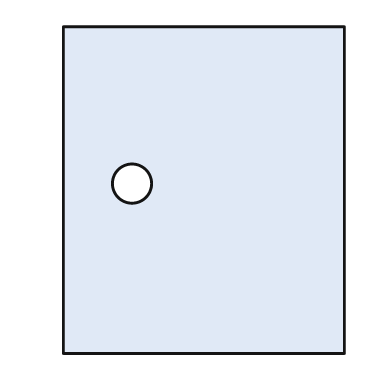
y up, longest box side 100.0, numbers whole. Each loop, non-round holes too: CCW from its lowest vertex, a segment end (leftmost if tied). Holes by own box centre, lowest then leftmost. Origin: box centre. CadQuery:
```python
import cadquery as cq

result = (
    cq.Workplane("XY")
    .moveTo(-43.0, -50.0)
    .lineTo(43.0, -50.0)
    .lineTo(43.0, 50.0)
    .lineTo(-43.0, 50.0)
    .close()
    .moveTo(-22.0, 2.0)
    .circle(6.0)
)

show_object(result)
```